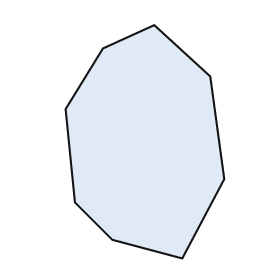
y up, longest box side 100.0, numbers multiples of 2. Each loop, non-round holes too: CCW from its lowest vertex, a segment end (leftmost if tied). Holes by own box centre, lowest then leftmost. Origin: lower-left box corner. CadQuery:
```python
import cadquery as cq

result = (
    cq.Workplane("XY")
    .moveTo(50.0, 0.0)
    .lineTo(68.0, 34.0)
    .lineTo(62.0, 78.0)
    .lineTo(38.0, 100.0)
    .lineTo(16.0, 90.0)
    .lineTo(0.0, 64.0)
    .lineTo(4.0, 24.0)
    .lineTo(20.0, 8.0)
    .close()
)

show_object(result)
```